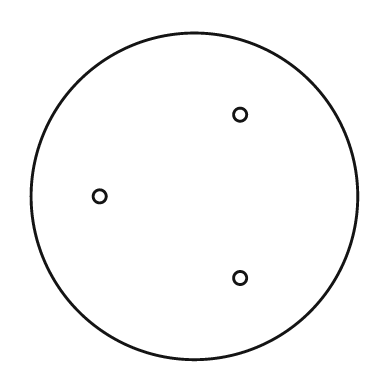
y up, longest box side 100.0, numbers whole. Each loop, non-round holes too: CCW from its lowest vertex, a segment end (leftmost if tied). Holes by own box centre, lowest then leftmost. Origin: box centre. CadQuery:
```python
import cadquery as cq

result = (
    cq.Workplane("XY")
    .moveTo(0.0, 0.0)
    .circle(50.0)
    .moveTo(14.0, -25.0)
    .circle(2.0)
    .moveTo(-29.0, 0.0)
    .circle(2.0)
    .moveTo(14.0, 25.0)
    .circle(2.0)
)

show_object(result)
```